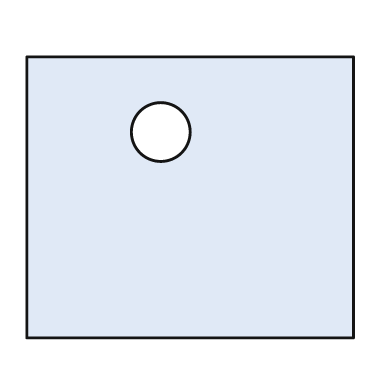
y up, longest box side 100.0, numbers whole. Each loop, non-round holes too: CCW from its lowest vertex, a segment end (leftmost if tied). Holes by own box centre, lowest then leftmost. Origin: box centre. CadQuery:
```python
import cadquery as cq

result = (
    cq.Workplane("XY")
    .moveTo(-50.0, -43.0)
    .lineTo(50.0, -43.0)
    .lineTo(50.0, 43.0)
    .lineTo(-50.0, 43.0)
    .close()
    .moveTo(-9.0, 20.0)
    .circle(9.0)
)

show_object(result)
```